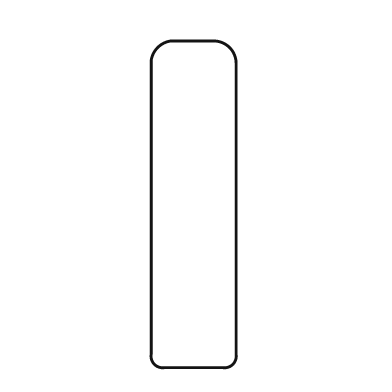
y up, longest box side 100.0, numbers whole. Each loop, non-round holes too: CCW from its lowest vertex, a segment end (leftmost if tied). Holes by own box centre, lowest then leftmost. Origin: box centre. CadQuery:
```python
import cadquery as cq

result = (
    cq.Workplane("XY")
    .moveTo(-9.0, -50.0)
    .lineTo(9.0, -50.0)
    .threePointArc((12.0, -49.0), (13.0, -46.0))
    .lineTo(13.0, 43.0)
    .threePointArc((11.0, 48.0), (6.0, 50.0))
    .lineTo(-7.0, 50.0)
    .threePointArc((-11.0, 48.0), (-13.0, 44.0))
    .lineTo(-13.0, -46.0)
    .threePointArc((-12.0, -49.0), (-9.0, -50.0))
    .close()
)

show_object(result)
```